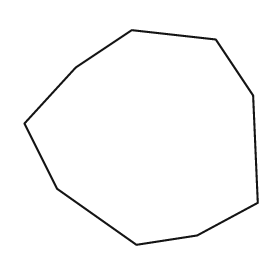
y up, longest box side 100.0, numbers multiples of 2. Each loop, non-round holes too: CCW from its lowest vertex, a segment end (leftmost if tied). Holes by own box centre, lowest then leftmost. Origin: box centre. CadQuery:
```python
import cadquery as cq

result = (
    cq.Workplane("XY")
    .moveTo(-2.0, -46.0)
    .lineTo(24.0, -42.0)
    .lineTo(50.0, -28.0)
    .lineTo(48.0, 18.0)
    .lineTo(32.0, 42.0)
    .lineTo(-4.0, 46.0)
    .lineTo(-28.0, 30.0)
    .lineTo(-50.0, 6.0)
    .lineTo(-36.0, -22.0)
    .close()
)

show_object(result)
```